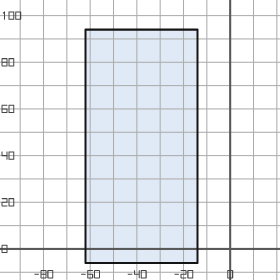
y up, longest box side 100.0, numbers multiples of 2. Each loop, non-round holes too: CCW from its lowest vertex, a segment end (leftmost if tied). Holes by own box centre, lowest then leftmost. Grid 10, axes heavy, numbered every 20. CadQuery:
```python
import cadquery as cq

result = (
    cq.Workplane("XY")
    .moveTo(-62.0, -6.0)
    .lineTo(-14.0, -6.0)
    .lineTo(-14.0, 94.0)
    .lineTo(-62.0, 94.0)
    .close()
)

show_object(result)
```